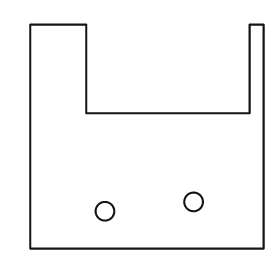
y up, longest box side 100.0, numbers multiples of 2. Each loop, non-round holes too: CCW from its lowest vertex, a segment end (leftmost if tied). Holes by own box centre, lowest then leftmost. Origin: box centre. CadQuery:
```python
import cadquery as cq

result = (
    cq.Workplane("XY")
    .moveTo(-50.0, -48.0)
    .lineTo(50.0, -48.0)
    .lineTo(50.0, 48.0)
    .lineTo(44.0, 48.0)
    .lineTo(44.0, 10.0)
    .lineTo(-26.0, 10.0)
    .lineTo(-26.0, 48.0)
    .lineTo(-50.0, 48.0)
    .close()
    .moveTo(-18.0, -32.0)
    .circle(4.0)
    .moveTo(20.0, -28.0)
    .circle(4.0)
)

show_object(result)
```